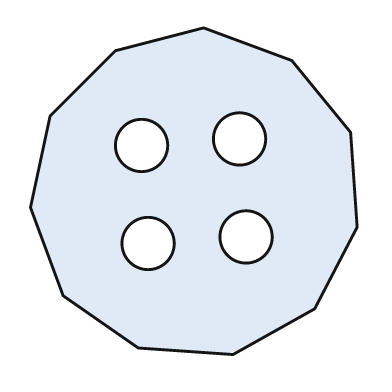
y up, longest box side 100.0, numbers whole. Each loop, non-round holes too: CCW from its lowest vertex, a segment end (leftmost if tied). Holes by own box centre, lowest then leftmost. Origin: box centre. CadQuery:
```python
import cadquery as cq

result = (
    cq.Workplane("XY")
    .moveTo(12.0, -50.0)
    .lineTo(37.0, -36.0)
    .lineTo(50.0, -11.0)
    .lineTo(48.0, 18.0)
    .lineTo(30.0, 40.0)
    .lineTo(3.0, 50.0)
    .lineTo(-24.0, 43.0)
    .lineTo(-44.0, 23.0)
    .lineTo(-50.0, -5.0)
    .lineTo(-40.0, -32.0)
    .lineTo(-17.0, -48.0)
    .close()
    .moveTo(-14.0, -16.0)
    .circle(8.0)
    .moveTo(16.0, -14.0)
    .circle(8.0)
    .moveTo(-16.0, 14.0)
    .circle(8.0)
    .moveTo(14.0, 16.0)
    .circle(8.0)
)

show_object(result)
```